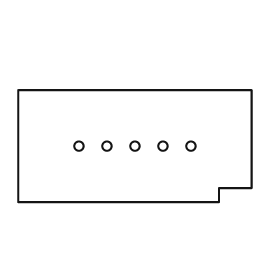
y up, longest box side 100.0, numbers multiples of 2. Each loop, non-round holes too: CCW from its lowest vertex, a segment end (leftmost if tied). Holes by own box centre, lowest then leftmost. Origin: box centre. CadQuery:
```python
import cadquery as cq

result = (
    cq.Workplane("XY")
    .moveTo(-50.0, -24.0)
    .lineTo(36.0, -24.0)
    .lineTo(36.0, -18.0)
    .lineTo(50.0, -18.0)
    .lineTo(50.0, 24.0)
    .lineTo(-50.0, 24.0)
    .close()
    .moveTo(-24.0, 0.0)
    .circle(2.0)
    .moveTo(-12.0, 0.0)
    .circle(2.0)
    .moveTo(0.0, 0.0)
    .circle(2.0)
    .moveTo(12.0, 0.0)
    .circle(2.0)
    .moveTo(24.0, 0.0)
    .circle(2.0)
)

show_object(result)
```